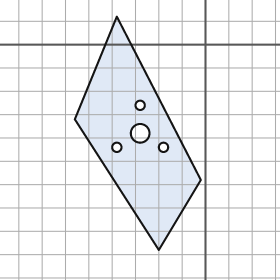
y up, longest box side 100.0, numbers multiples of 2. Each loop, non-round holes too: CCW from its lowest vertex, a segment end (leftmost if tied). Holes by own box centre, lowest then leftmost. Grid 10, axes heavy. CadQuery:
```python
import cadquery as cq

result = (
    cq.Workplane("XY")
    .moveTo(-20.0, -88.0)
    .lineTo(-2.0, -58.0)
    .lineTo(-38.0, 12.0)
    .lineTo(-56.0, -32.0)
    .close()
    .moveTo(-38.0, -44.0)
    .circle(2.0)
    .moveTo(-18.0, -44.0)
    .circle(2.0)
    .moveTo(-28.0, -38.0)
    .circle(4.0)
    .moveTo(-28.0, -26.0)
    .circle(2.0)
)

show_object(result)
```